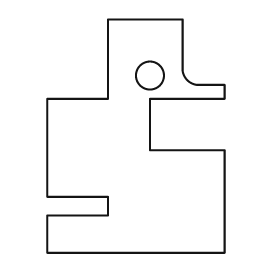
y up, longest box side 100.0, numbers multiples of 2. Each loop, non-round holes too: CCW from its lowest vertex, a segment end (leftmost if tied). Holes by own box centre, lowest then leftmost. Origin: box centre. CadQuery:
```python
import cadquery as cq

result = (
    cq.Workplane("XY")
    .moveTo(-38.0, -50.0)
    .lineTo(38.0, -50.0)
    .lineTo(38.0, -6.0)
    .lineTo(6.0, -6.0)
    .lineTo(6.0, 16.0)
    .lineTo(38.0, 16.0)
    .lineTo(38.0, 22.0)
    .lineTo(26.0, 22.0)
    .threePointArc((22.0, 24.0), (20.0, 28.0))
    .lineTo(20.0, 50.0)
    .lineTo(-12.0, 50.0)
    .lineTo(-12.0, 16.0)
    .lineTo(-38.0, 16.0)
    .lineTo(-38.0, -26.0)
    .lineTo(-12.0, -26.0)
    .lineTo(-12.0, -34.0)
    .lineTo(-38.0, -34.0)
    .close()
    .moveTo(6.0, 26.0)
    .circle(6.0)
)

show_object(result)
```